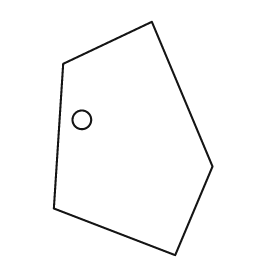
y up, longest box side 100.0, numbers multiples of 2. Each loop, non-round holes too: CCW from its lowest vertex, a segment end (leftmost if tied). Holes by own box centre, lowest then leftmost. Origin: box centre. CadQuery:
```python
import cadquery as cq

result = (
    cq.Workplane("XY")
    .moveTo(18.0, -50.0)
    .lineTo(34.0, -12.0)
    .lineTo(8.0, 50.0)
    .lineTo(-30.0, 32.0)
    .lineTo(-34.0, -30.0)
    .close()
    .moveTo(-22.0, 8.0)
    .circle(4.0)
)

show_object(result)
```